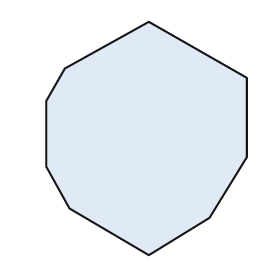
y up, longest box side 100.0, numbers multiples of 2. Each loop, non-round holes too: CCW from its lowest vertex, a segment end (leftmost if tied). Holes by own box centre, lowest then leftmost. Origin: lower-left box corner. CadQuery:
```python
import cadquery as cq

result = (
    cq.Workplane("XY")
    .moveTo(44.0, 0.0)
    .lineTo(70.0, 16.0)
    .lineTo(86.0, 42.0)
    .lineTo(86.0, 76.0)
    .lineTo(44.0, 100.0)
    .lineTo(8.0, 80.0)
    .lineTo(0.0, 66.0)
    .lineTo(0.0, 38.0)
    .lineTo(10.0, 20.0)
    .close()
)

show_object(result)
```